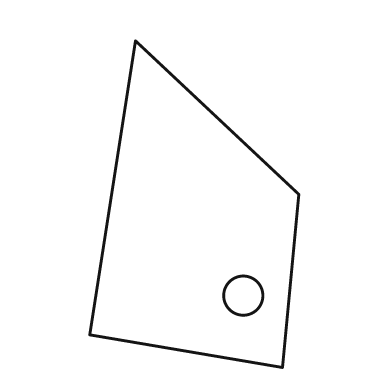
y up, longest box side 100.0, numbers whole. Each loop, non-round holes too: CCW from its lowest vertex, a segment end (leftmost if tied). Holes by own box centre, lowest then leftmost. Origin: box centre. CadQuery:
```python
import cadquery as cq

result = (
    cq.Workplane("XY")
    .moveTo(27.0, -50.0)
    .lineTo(32.0, 3.0)
    .lineTo(-18.0, 50.0)
    .lineTo(-32.0, -40.0)
    .close()
    .moveTo(15.0, -28.0)
    .circle(6.0)
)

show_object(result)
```